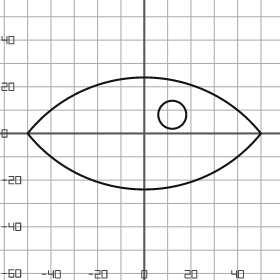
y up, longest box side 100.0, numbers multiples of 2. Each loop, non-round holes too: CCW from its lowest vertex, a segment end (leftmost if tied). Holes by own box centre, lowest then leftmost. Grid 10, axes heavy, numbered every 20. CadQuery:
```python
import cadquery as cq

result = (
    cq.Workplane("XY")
    .moveTo(-50.0, 0.0)
    .threePointArc((0.0, -24.0), (50.0, 0.0))
    .threePointArc((0.0, 24.0), (-50.0, 0.0))
    .close()
    .moveTo(12.0, 8.0)
    .circle(6.0)
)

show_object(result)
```